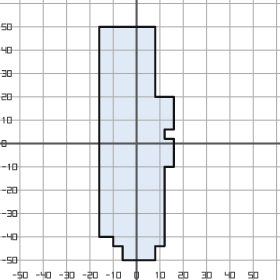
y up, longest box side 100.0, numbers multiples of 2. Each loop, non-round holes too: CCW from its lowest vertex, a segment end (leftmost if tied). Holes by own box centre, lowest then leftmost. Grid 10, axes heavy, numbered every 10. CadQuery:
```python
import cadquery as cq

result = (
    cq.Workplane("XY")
    .moveTo(-6.0, -50.0)
    .lineTo(8.0, -50.0)
    .lineTo(8.0, -44.0)
    .lineTo(12.0, -44.0)
    .lineTo(12.0, -10.0)
    .lineTo(16.0, -10.0)
    .lineTo(16.0, 2.0)
    .lineTo(12.0, 2.0)
    .lineTo(12.0, 6.0)
    .lineTo(16.0, 6.0)
    .lineTo(16.0, 20.0)
    .lineTo(8.0, 20.0)
    .lineTo(8.0, 50.0)
    .lineTo(-16.0, 50.0)
    .lineTo(-16.0, -40.0)
    .lineTo(-10.0, -40.0)
    .lineTo(-10.0, -44.0)
    .lineTo(-6.0, -44.0)
    .close()
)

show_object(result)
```